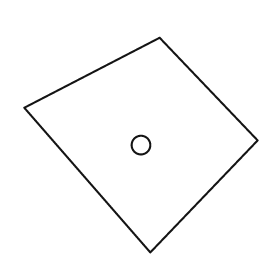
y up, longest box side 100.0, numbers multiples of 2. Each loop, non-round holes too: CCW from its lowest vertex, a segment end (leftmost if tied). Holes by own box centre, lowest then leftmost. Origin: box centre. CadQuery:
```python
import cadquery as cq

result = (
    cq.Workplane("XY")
    .moveTo(4.0, -46.0)
    .lineTo(50.0, 2.0)
    .lineTo(8.0, 46.0)
    .lineTo(-50.0, 16.0)
    .close()
    .moveTo(0.0, 0.0)
    .circle(4.0)
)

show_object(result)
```